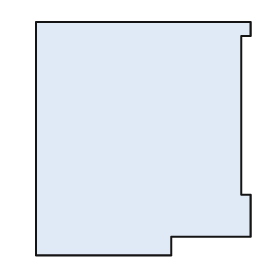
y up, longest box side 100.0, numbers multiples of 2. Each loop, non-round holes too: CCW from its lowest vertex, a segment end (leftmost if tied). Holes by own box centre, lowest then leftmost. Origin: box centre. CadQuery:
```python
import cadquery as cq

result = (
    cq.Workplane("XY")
    .moveTo(-46.0, -50.0)
    .lineTo(12.0, -50.0)
    .lineTo(12.0, -42.0)
    .lineTo(46.0, -42.0)
    .lineTo(46.0, -24.0)
    .lineTo(42.0, -24.0)
    .lineTo(42.0, 44.0)
    .lineTo(46.0, 44.0)
    .lineTo(46.0, 50.0)
    .lineTo(-46.0, 50.0)
    .close()
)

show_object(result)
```